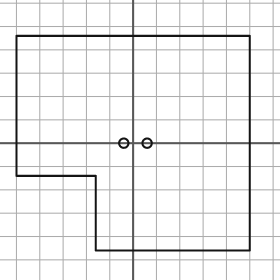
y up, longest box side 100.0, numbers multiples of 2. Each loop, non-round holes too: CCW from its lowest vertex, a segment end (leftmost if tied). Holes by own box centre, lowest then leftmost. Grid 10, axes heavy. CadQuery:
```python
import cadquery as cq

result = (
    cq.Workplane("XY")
    .moveTo(-16.0, -46.0)
    .lineTo(50.0, -46.0)
    .lineTo(50.0, 46.0)
    .lineTo(-50.0, 46.0)
    .lineTo(-50.0, -14.0)
    .lineTo(-16.0, -14.0)
    .close()
    .moveTo(-4.0, 0.0)
    .circle(2.0)
    .moveTo(6.0, 0.0)
    .circle(2.0)
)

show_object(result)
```